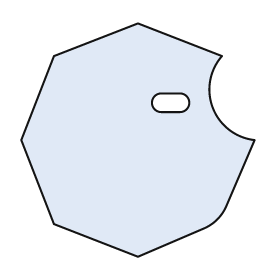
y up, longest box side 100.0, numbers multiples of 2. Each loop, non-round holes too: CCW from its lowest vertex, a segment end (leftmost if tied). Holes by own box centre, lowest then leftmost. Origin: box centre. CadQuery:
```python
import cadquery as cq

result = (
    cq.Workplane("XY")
    .moveTo(0.0, -50.0)
    .lineTo(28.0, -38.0)
    .threePointArc((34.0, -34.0), (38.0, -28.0))
    .lineTo(50.0, 0.0)
    .threePointArc((32.0, 14.0), (36.0, 36.0))
    .lineTo(0.0, 50.0)
    .lineTo(-36.0, 36.0)
    .lineTo(-50.0, 0.0)
    .lineTo(-36.0, -36.0)
    .close()
    .moveTo(10.0, 12.0)
    .lineTo(18.0, 12.0)
    .threePointArc((22.0, 16.0), (18.0, 20.0))
    .lineTo(10.0, 20.0)
    .threePointArc((6.0, 16.0), (10.0, 12.0))
    .close()
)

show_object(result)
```